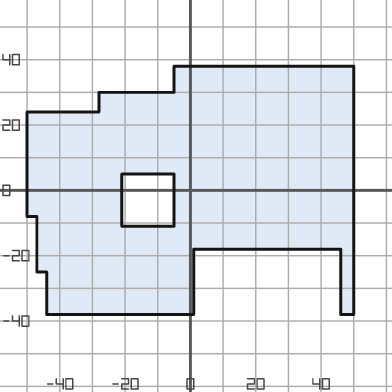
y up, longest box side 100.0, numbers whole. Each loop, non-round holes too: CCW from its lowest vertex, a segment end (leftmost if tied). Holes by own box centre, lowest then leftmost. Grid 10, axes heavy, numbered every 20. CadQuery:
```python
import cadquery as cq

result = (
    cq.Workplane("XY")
    .moveTo(-44.0, -38.0)
    .lineTo(1.0, -38.0)
    .lineTo(1.0, -18.0)
    .lineTo(46.0, -18.0)
    .lineTo(46.0, -38.0)
    .lineTo(50.0, -38.0)
    .lineTo(50.0, 38.0)
    .lineTo(-5.0, 38.0)
    .lineTo(-5.0, 30.0)
    .lineTo(-28.0, 30.0)
    .lineTo(-28.0, 24.0)
    .lineTo(-50.0, 24.0)
    .lineTo(-50.0, -8.0)
    .lineTo(-47.0, -8.0)
    .lineTo(-47.0, -25.0)
    .lineTo(-44.0, -25.0)
    .close()
    .moveTo(-21.0, -11.0)
    .lineTo(-5.0, -11.0)
    .lineTo(-5.0, 5.0)
    .lineTo(-21.0, 5.0)
    .close()
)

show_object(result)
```